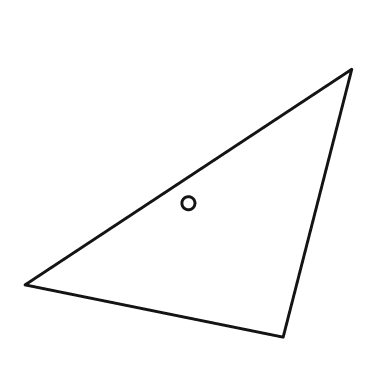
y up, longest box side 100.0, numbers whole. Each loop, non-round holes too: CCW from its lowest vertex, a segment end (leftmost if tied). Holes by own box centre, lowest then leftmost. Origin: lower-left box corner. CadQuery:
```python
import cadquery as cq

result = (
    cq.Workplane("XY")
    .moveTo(79.0, 0.0)
    .lineTo(100.0, 82.0)
    .lineTo(0.0, 16.0)
    .close()
    .moveTo(50.0, 41.0)
    .circle(2.0)
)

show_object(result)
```